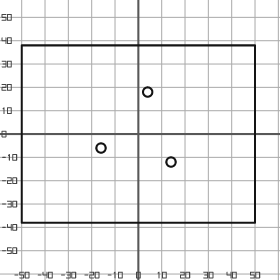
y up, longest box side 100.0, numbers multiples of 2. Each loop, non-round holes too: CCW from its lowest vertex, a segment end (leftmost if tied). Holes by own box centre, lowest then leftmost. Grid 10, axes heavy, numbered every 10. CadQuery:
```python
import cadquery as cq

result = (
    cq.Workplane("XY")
    .moveTo(-50.0, -38.0)
    .lineTo(50.0, -38.0)
    .lineTo(50.0, 38.0)
    .lineTo(-50.0, 38.0)
    .close()
    .moveTo(14.0, -12.0)
    .circle(2.0)
    .moveTo(-16.0, -6.0)
    .circle(2.0)
    .moveTo(4.0, 18.0)
    .circle(2.0)
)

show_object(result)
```